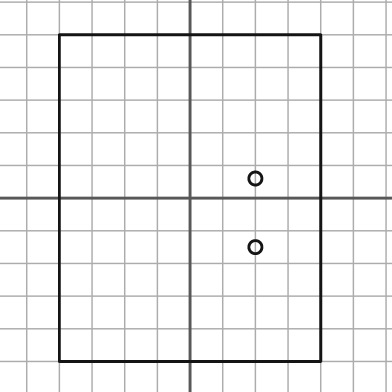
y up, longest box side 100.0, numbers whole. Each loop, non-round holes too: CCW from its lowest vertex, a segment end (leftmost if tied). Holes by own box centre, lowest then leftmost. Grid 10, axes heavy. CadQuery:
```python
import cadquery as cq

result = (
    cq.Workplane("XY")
    .moveTo(-40.0, -50.0)
    .lineTo(40.0, -50.0)
    .lineTo(40.0, 50.0)
    .lineTo(-40.0, 50.0)
    .close()
    .moveTo(20.0, -15.0)
    .circle(2.0)
    .moveTo(20.0, 6.0)
    .circle(2.0)
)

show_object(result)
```